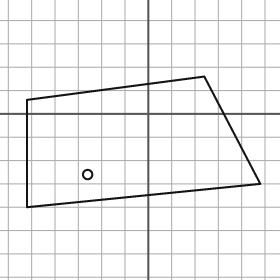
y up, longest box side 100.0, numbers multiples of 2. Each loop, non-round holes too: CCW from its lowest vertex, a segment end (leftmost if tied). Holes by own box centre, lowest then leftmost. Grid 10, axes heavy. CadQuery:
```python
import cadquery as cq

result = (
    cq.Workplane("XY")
    .moveTo(-52.0, -40.0)
    .lineTo(48.0, -30.0)
    .lineTo(24.0, 16.0)
    .lineTo(-52.0, 6.0)
    .close()
    .moveTo(-26.0, -26.0)
    .circle(2.0)
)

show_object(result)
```